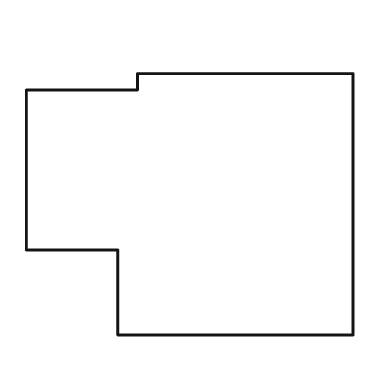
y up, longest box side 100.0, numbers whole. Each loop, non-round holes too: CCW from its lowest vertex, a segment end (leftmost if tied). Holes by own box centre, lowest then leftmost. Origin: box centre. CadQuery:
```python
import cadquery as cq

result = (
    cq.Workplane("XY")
    .moveTo(-22.0, -40.0)
    .lineTo(50.0, -40.0)
    .lineTo(50.0, 40.0)
    .lineTo(-16.0, 40.0)
    .lineTo(-16.0, 35.0)
    .lineTo(-50.0, 35.0)
    .lineTo(-50.0, -14.0)
    .lineTo(-22.0, -14.0)
    .close()
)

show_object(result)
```